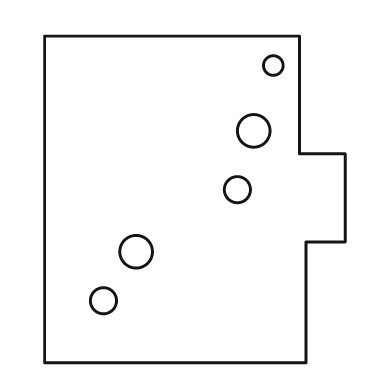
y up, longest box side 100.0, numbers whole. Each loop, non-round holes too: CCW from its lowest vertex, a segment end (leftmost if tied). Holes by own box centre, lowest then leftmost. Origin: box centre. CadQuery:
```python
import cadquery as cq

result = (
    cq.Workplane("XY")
    .moveTo(-46.0, -50.0)
    .lineTo(34.0, -50.0)
    .lineTo(34.0, -13.0)
    .lineTo(46.0, -13.0)
    .lineTo(46.0, 14.0)
    .lineTo(32.0, 14.0)
    .lineTo(32.0, 50.0)
    .lineTo(-46.0, 50.0)
    .close()
    .moveTo(-28.0, -31.0)
    .circle(4.0)
    .moveTo(-18.0, -16.0)
    .circle(5.0)
    .moveTo(13.0, 3.0)
    .circle(4.0)
    .moveTo(18.0, 21.0)
    .circle(5.0)
    .moveTo(24.0, 41.0)
    .circle(3.0)
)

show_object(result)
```